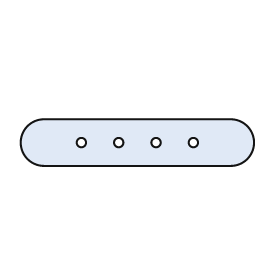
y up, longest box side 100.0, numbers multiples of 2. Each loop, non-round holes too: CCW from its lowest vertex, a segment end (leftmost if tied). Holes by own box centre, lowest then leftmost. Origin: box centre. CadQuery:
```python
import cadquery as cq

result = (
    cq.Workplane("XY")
    .moveTo(-40.0, -10.0)
    .lineTo(40.0, -10.0)
    .threePointArc((50.0, 0.0), (40.0, 10.0))
    .lineTo(-40.0, 10.0)
    .threePointArc((-50.0, 0.0), (-40.0, -10.0))
    .close()
    .moveTo(-24.0, 0.0)
    .circle(2.0)
    .moveTo(-8.0, 0.0)
    .circle(2.0)
    .moveTo(8.0, 0.0)
    .circle(2.0)
    .moveTo(24.0, 0.0)
    .circle(2.0)
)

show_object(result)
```